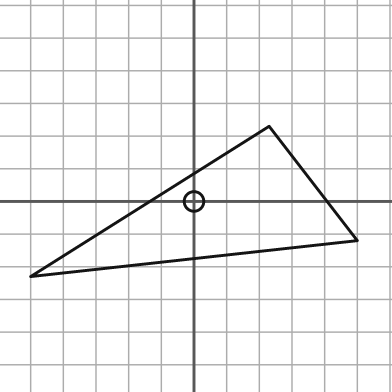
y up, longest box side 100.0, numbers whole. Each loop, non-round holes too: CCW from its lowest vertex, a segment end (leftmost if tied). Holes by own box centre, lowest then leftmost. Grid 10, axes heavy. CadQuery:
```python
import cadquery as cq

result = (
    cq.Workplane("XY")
    .moveTo(-50.0, -23.0)
    .lineTo(50.0, -12.0)
    .lineTo(23.0, 23.0)
    .close()
    .moveTo(0.0, 0.0)
    .circle(3.0)
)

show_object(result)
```